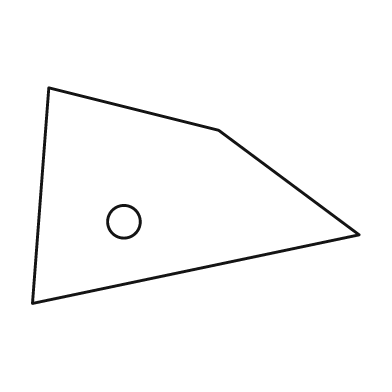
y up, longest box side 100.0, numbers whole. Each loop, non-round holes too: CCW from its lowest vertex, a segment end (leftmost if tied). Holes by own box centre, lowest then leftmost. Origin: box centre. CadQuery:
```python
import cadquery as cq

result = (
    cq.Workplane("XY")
    .moveTo(-50.0, -33.0)
    .lineTo(50.0, -12.0)
    .lineTo(7.0, 20.0)
    .lineTo(-45.0, 33.0)
    .close()
    .moveTo(-22.0, -8.0)
    .circle(5.0)
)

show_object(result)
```